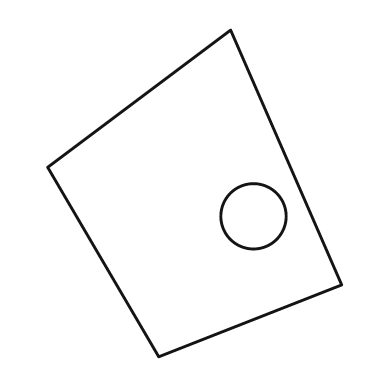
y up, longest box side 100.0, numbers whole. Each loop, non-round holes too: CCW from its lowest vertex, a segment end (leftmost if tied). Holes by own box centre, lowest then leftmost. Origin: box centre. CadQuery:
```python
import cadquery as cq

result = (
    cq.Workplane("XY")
    .moveTo(-11.0, -50.0)
    .lineTo(45.0, -28.0)
    .lineTo(11.0, 50.0)
    .lineTo(-45.0, 8.0)
    .close()
    .moveTo(18.0, -7.0)
    .circle(10.0)
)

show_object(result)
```